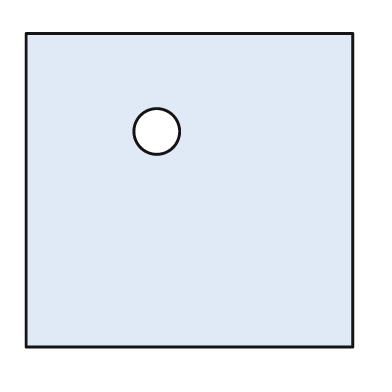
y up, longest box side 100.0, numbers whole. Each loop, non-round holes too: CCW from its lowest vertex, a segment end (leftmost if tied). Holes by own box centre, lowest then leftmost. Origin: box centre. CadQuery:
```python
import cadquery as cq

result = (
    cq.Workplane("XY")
    .moveTo(-50.0, -48.0)
    .lineTo(50.0, -48.0)
    .lineTo(50.0, 48.0)
    .lineTo(-50.0, 48.0)
    .close()
    .moveTo(-10.0, 18.0)
    .circle(7.0)
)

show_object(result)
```